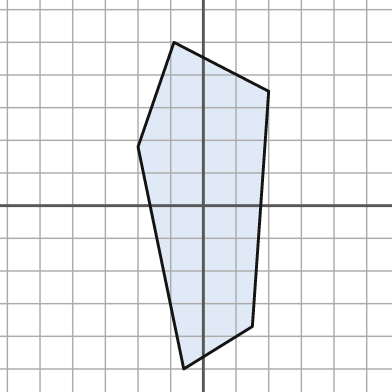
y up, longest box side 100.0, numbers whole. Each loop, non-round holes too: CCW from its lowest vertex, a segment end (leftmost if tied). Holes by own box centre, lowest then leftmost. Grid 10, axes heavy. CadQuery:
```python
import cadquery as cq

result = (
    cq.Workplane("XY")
    .moveTo(-6.0, -50.0)
    .lineTo(15.0, -37.0)
    .lineTo(20.0, 35.0)
    .lineTo(-9.0, 50.0)
    .lineTo(-20.0, 18.0)
    .close()
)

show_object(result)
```